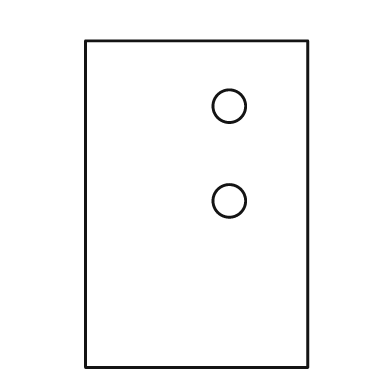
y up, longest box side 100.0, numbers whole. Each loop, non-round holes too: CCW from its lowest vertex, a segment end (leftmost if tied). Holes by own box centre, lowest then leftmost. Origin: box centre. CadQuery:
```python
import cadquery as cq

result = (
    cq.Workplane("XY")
    .moveTo(-34.0, -50.0)
    .lineTo(34.0, -50.0)
    .lineTo(34.0, 50.0)
    .lineTo(-34.0, 50.0)
    .close()
    .moveTo(10.0, 1.0)
    .circle(5.0)
    .moveTo(10.0, 30.0)
    .circle(5.0)
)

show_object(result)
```